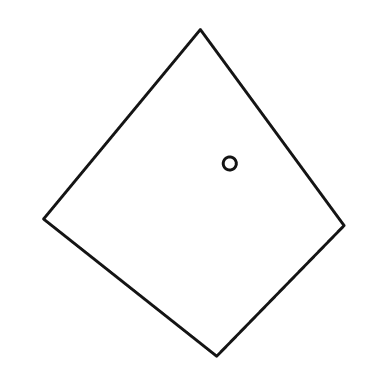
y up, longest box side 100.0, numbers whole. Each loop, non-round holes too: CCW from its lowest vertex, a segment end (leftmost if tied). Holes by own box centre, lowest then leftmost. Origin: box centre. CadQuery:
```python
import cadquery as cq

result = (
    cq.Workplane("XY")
    .moveTo(7.0, -50.0)
    .lineTo(46.0, -10.0)
    .lineTo(2.0, 50.0)
    .lineTo(-46.0, -8.0)
    .close()
    .moveTo(11.0, 9.0)
    .circle(2.0)
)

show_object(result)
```